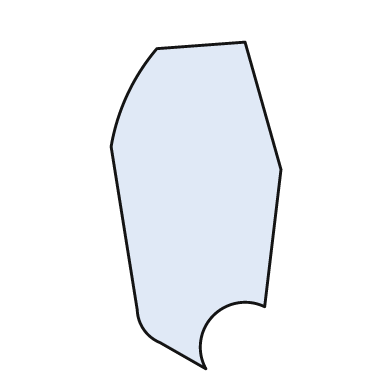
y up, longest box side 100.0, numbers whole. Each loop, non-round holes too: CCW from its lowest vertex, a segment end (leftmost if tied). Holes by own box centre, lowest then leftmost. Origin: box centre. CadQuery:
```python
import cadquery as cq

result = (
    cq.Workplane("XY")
    .moveTo(3.0, -50.0)
    .threePointArc((5.0, -34.0), (21.0, -31.0))
    .lineTo(26.0, 11.0)
    .lineTo(15.0, 50.0)
    .lineTo(-12.0, 48.0)
    .threePointArc((-21.0, 34.0), (-26.0, 18.0))
    .lineTo(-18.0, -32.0)
    .threePointArc((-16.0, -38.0), (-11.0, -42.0))
    .close()
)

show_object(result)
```